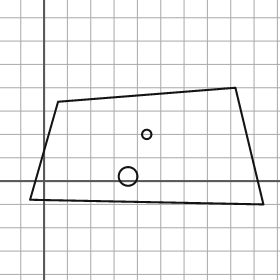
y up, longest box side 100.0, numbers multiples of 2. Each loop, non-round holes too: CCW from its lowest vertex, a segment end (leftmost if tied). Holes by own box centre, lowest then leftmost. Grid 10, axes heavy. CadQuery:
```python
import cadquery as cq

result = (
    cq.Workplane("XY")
    .moveTo(94.0, -10.0)
    .lineTo(82.0, 40.0)
    .lineTo(6.0, 34.0)
    .lineTo(-6.0, -8.0)
    .close()
    .moveTo(36.0, 2.0)
    .circle(4.0)
    .moveTo(44.0, 20.0)
    .circle(2.0)
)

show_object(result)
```